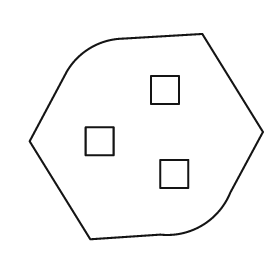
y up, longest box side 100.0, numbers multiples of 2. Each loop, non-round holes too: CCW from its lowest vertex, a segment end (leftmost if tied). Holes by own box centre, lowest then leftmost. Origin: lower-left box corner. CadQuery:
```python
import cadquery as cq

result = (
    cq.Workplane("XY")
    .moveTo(26.0, 0.0)
    .lineTo(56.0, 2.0)
    .threePointArc((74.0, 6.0), (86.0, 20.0))
    .lineTo(100.0, 46.0)
    .lineTo(74.0, 88.0)
    .lineTo(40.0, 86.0)
    .threePointArc((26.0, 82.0), (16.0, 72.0))
    .lineTo(0.0, 42.0)
    .close()
    .moveTo(56.0, 22.0)
    .lineTo(68.0, 22.0)
    .lineTo(68.0, 34.0)
    .lineTo(56.0, 34.0)
    .close()
    .moveTo(24.0, 36.0)
    .lineTo(36.0, 36.0)
    .lineTo(36.0, 48.0)
    .lineTo(24.0, 48.0)
    .close()
    .moveTo(52.0, 58.0)
    .lineTo(64.0, 58.0)
    .lineTo(64.0, 70.0)
    .lineTo(52.0, 70.0)
    .close()
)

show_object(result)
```